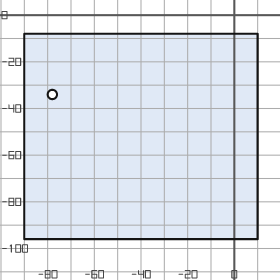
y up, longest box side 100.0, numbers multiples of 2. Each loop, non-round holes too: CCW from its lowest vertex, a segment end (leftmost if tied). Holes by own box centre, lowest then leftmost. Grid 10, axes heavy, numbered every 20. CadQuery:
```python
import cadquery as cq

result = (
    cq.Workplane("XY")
    .moveTo(-90.0, -96.0)
    .lineTo(10.0, -96.0)
    .lineTo(10.0, -8.0)
    .lineTo(-90.0, -8.0)
    .close()
    .moveTo(-78.0, -34.0)
    .circle(2.0)
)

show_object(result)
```